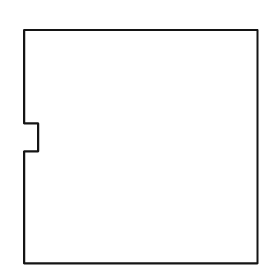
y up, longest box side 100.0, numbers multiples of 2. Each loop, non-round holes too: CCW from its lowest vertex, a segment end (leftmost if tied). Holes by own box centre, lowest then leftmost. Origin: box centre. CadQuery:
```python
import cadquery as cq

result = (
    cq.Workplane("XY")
    .moveTo(-50.0, -50.0)
    .lineTo(50.0, -50.0)
    .lineTo(50.0, 50.0)
    .lineTo(-50.0, 50.0)
    .lineTo(-50.0, 10.0)
    .lineTo(-44.0, 10.0)
    .lineTo(-44.0, -2.0)
    .lineTo(-50.0, -2.0)
    .close()
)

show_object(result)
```